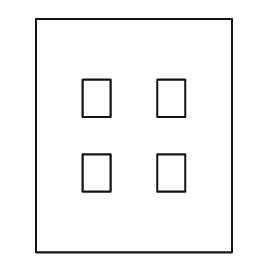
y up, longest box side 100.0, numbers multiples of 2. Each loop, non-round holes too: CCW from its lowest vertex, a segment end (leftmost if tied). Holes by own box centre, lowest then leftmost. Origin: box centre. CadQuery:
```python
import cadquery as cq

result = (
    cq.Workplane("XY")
    .moveTo(-42.0, -50.0)
    .lineTo(42.0, -50.0)
    .lineTo(42.0, 50.0)
    .lineTo(-42.0, 50.0)
    .close()
    .moveTo(-22.0, -24.0)
    .lineTo(-10.0, -24.0)
    .lineTo(-10.0, -8.0)
    .lineTo(-22.0, -8.0)
    .close()
    .moveTo(10.0, -24.0)
    .lineTo(22.0, -24.0)
    .lineTo(22.0, -8.0)
    .lineTo(10.0, -8.0)
    .close()
    .moveTo(-22.0, 8.0)
    .lineTo(-10.0, 8.0)
    .lineTo(-10.0, 24.0)
    .lineTo(-22.0, 24.0)
    .close()
    .moveTo(10.0, 8.0)
    .lineTo(22.0, 8.0)
    .lineTo(22.0, 24.0)
    .lineTo(10.0, 24.0)
    .close()
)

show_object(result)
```